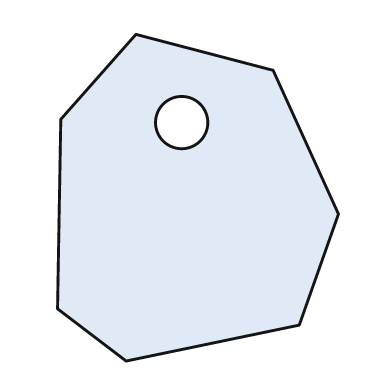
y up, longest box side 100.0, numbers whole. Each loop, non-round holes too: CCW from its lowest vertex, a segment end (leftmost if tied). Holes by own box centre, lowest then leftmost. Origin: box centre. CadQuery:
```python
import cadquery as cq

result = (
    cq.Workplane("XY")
    .moveTo(-22.0, -50.0)
    .lineTo(31.0, -39.0)
    .lineTo(43.0, -5.0)
    .lineTo(23.0, 39.0)
    .lineTo(-19.0, 50.0)
    .lineTo(-42.0, 24.0)
    .lineTo(-43.0, -34.0)
    .close()
    .moveTo(-5.0, 23.0)
    .circle(8.0)
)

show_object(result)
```